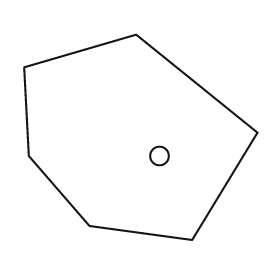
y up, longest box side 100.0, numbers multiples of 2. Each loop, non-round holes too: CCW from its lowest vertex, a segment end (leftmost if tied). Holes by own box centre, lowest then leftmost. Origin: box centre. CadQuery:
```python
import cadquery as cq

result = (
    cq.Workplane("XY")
    .moveTo(22.0, -44.0)
    .lineTo(50.0, 2.0)
    .lineTo(-2.0, 44.0)
    .lineTo(-50.0, 30.0)
    .lineTo(-48.0, -8.0)
    .lineTo(-22.0, -38.0)
    .close()
    .moveTo(8.0, -8.0)
    .circle(4.0)
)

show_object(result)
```